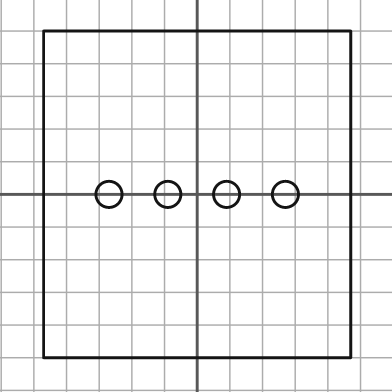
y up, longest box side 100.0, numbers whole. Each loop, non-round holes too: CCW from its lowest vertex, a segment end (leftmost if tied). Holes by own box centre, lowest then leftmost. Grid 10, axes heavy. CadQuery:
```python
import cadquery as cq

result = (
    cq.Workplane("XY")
    .moveTo(-47.0, -50.0)
    .lineTo(47.0, -50.0)
    .lineTo(47.0, 50.0)
    .lineTo(-47.0, 50.0)
    .close()
    .moveTo(-27.0, 0.0)
    .circle(4.0)
    .moveTo(-9.0, 0.0)
    .circle(4.0)
    .moveTo(9.0, 0.0)
    .circle(4.0)
    .moveTo(27.0, 0.0)
    .circle(4.0)
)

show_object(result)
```